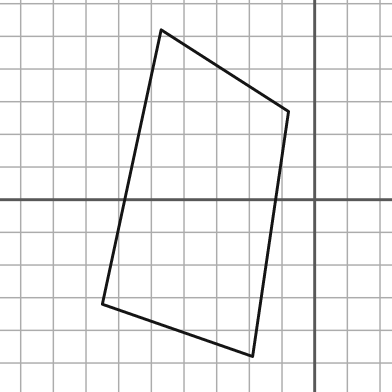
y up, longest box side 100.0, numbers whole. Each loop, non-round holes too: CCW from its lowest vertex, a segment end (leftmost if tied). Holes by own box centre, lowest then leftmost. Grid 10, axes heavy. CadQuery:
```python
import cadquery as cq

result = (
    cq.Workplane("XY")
    .moveTo(-19.0, -48.0)
    .lineTo(-8.0, 27.0)
    .lineTo(-47.0, 52.0)
    .lineTo(-65.0, -32.0)
    .close()
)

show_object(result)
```